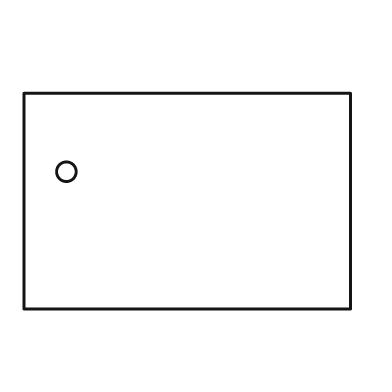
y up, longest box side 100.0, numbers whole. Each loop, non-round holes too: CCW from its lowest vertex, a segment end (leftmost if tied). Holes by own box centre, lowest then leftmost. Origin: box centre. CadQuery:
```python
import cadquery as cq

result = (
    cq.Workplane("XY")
    .moveTo(-50.0, -33.0)
    .lineTo(50.0, -33.0)
    .lineTo(50.0, 33.0)
    .lineTo(-50.0, 33.0)
    .close()
    .moveTo(-37.0, 9.0)
    .circle(3.0)
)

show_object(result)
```